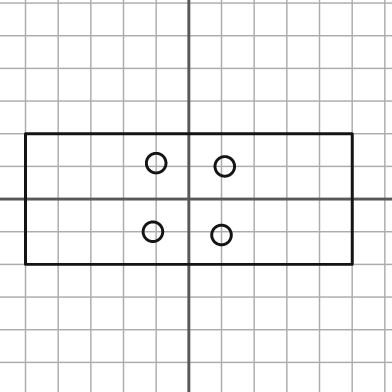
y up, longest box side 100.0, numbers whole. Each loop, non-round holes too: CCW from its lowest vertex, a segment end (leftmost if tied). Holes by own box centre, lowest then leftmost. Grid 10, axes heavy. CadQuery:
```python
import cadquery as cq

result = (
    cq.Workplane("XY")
    .moveTo(-50.0, -20.0)
    .lineTo(50.0, -20.0)
    .lineTo(50.0, 20.0)
    .lineTo(-50.0, 20.0)
    .close()
    .moveTo(10.0, -11.0)
    .circle(3.0)
    .moveTo(-11.0, -10.0)
    .circle(3.0)
    .moveTo(11.0, 10.0)
    .circle(3.0)
    .moveTo(-10.0, 11.0)
    .circle(3.0)
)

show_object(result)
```